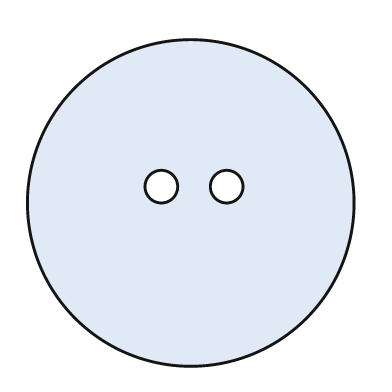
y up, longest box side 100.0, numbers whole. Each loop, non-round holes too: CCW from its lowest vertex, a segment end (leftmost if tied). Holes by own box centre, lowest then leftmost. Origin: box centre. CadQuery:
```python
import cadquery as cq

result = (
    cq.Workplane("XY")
    .moveTo(0.0, 0.0)
    .circle(50.0)
    .moveTo(-9.0, 5.0)
    .circle(5.0)
    .moveTo(11.0, 5.0)
    .circle(5.0)
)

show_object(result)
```